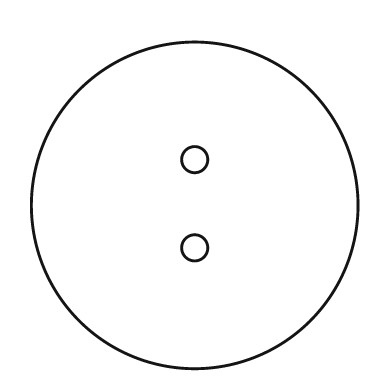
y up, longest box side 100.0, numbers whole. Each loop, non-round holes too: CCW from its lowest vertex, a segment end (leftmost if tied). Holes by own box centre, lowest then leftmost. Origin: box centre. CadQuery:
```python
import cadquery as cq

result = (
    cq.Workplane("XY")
    .moveTo(0.0, 0.0)
    .circle(50.0)
    .moveTo(0.0, -13.0)
    .circle(4.0)
    .moveTo(0.0, 14.0)
    .circle(4.0)
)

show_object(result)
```